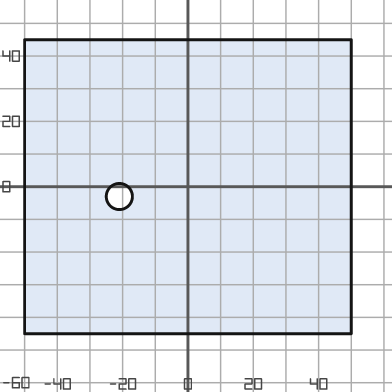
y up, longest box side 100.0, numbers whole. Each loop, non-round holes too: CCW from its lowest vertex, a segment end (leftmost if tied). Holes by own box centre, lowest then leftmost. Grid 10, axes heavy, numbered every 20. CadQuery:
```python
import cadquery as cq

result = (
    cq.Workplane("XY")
    .moveTo(-50.0, -45.0)
    .lineTo(50.0, -45.0)
    .lineTo(50.0, 45.0)
    .lineTo(-50.0, 45.0)
    .close()
    .moveTo(-21.0, -3.0)
    .circle(4.0)
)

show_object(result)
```